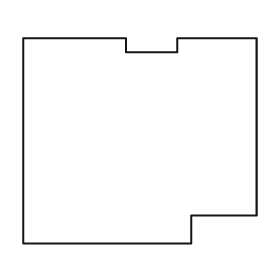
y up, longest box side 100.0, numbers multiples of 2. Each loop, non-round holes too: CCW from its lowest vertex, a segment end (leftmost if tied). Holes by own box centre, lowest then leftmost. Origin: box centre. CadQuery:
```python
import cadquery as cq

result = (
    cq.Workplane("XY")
    .moveTo(-50.0, -44.0)
    .lineTo(22.0, -44.0)
    .lineTo(22.0, -32.0)
    .lineTo(50.0, -32.0)
    .lineTo(50.0, 44.0)
    .lineTo(16.0, 44.0)
    .lineTo(16.0, 38.0)
    .lineTo(-6.0, 38.0)
    .lineTo(-6.0, 44.0)
    .lineTo(-50.0, 44.0)
    .close()
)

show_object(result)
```